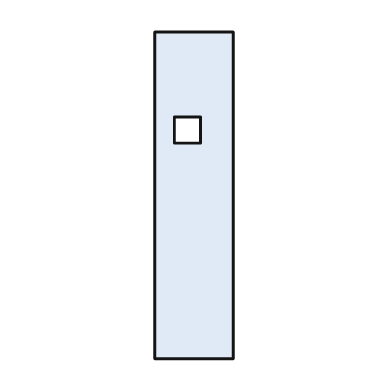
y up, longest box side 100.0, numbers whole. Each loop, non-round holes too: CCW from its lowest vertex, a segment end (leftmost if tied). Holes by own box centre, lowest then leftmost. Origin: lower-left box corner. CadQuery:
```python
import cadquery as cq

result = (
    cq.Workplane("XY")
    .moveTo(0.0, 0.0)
    .lineTo(24.0, 0.0)
    .lineTo(24.0, 100.0)
    .lineTo(0.0, 100.0)
    .close()
    .moveTo(6.0, 66.0)
    .lineTo(14.0, 66.0)
    .lineTo(14.0, 74.0)
    .lineTo(6.0, 74.0)
    .close()
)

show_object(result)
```